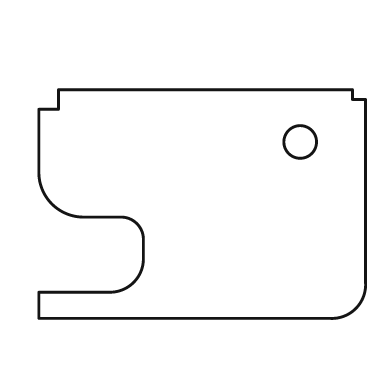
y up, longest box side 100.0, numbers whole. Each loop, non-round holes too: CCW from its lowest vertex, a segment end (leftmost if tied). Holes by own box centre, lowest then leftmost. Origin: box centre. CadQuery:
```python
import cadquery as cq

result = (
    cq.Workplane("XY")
    .moveTo(-50.0, -35.0)
    .lineTo(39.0, -35.0)
    .threePointArc((47.0, -32.0), (50.0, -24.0))
    .lineTo(50.0, 32.0)
    .lineTo(46.0, 32.0)
    .lineTo(46.0, 35.0)
    .lineTo(-44.0, 35.0)
    .lineTo(-44.0, 29.0)
    .lineTo(-50.0, 29.0)
    .lineTo(-50.0, 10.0)
    .threePointArc((-46.0, 0.0), (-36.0, -4.0))
    .lineTo(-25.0, -4.0)
    .threePointArc((-20.0, -6.0), (-18.0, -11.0))
    .lineTo(-18.0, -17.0)
    .threePointArc((-21.0, -24.0), (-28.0, -27.0))
    .lineTo(-50.0, -27.0)
    .close()
    .moveTo(30.0, 19.0)
    .circle(5.0)
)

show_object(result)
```